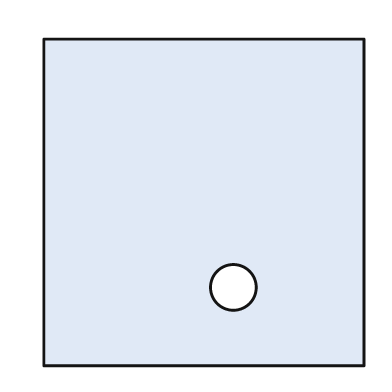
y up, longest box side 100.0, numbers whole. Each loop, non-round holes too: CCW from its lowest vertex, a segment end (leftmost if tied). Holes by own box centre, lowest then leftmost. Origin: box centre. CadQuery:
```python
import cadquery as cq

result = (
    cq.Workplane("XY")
    .moveTo(-49.0, -50.0)
    .lineTo(49.0, -50.0)
    .lineTo(49.0, 50.0)
    .lineTo(-49.0, 50.0)
    .close()
    .moveTo(9.0, -26.0)
    .circle(7.0)
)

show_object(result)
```